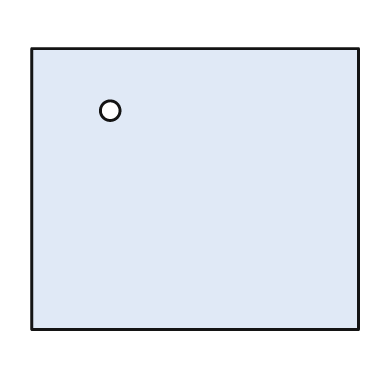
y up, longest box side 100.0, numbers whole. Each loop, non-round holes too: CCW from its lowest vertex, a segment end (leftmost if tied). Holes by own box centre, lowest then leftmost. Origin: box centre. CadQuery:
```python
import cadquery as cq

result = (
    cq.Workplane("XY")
    .moveTo(-50.0, -43.0)
    .lineTo(50.0, -43.0)
    .lineTo(50.0, 43.0)
    .lineTo(-50.0, 43.0)
    .close()
    .moveTo(-26.0, 24.0)
    .circle(3.0)
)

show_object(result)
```